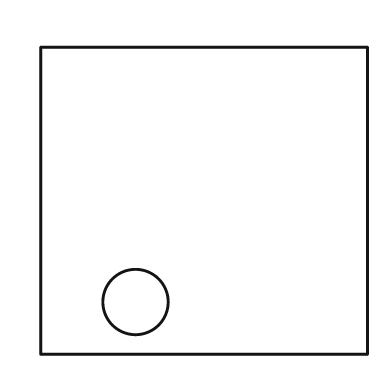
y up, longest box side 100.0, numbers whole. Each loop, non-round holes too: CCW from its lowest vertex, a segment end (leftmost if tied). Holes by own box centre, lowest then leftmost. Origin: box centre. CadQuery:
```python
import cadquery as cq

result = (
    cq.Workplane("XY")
    .moveTo(-50.0, -47.0)
    .lineTo(50.0, -47.0)
    .lineTo(50.0, 47.0)
    .lineTo(-50.0, 47.0)
    .close()
    .moveTo(-21.0, -31.0)
    .circle(10.0)
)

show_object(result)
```